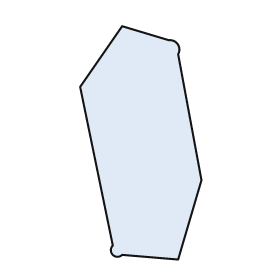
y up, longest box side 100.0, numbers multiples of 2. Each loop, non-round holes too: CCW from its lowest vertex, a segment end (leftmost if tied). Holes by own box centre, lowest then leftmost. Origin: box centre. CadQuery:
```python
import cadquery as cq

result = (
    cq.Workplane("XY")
    .moveTo(16.0, -50.0)
    .lineTo(26.0, -16.0)
    .lineTo(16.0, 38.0)
    .threePointArc((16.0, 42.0), (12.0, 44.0))
    .lineTo(-8.0, 50.0)
    .lineTo(-26.0, 24.0)
    .lineTo(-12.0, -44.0)
    .threePointArc((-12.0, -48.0), (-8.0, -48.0))
    .close()
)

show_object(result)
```